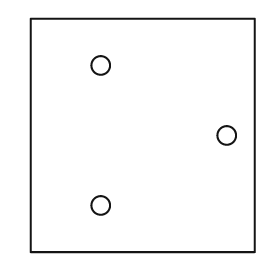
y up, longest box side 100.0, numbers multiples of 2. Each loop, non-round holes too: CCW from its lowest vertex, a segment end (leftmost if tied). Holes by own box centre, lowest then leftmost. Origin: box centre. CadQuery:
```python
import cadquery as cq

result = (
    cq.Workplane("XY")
    .moveTo(-48.0, -50.0)
    .lineTo(48.0, -50.0)
    .lineTo(48.0, 50.0)
    .lineTo(-48.0, 50.0)
    .close()
    .moveTo(-18.0, -30.0)
    .circle(4.0)
    .moveTo(36.0, 0.0)
    .circle(4.0)
    .moveTo(-18.0, 30.0)
    .circle(4.0)
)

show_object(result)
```